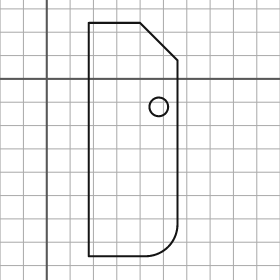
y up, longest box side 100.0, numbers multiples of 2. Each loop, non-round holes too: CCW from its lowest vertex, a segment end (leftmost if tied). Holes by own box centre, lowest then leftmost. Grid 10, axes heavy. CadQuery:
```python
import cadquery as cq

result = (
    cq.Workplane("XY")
    .moveTo(18.0, -76.0)
    .lineTo(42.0, -76.0)
    .threePointArc((52.0, -72.0), (56.0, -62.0))
    .lineTo(56.0, 8.0)
    .lineTo(40.0, 24.0)
    .lineTo(18.0, 24.0)
    .close()
    .moveTo(48.0, -12.0)
    .circle(4.0)
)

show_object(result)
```